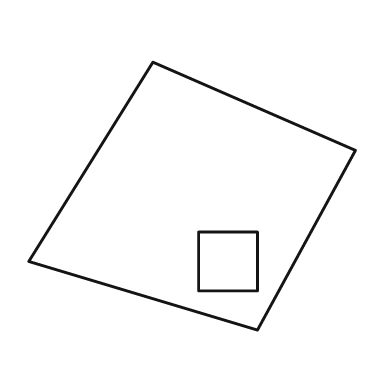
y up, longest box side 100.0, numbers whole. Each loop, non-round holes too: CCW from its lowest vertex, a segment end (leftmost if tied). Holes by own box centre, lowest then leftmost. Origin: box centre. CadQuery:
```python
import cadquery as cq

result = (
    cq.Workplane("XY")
    .moveTo(20.0, -41.0)
    .lineTo(50.0, 14.0)
    .lineTo(-12.0, 41.0)
    .lineTo(-50.0, -20.0)
    .close()
    .moveTo(2.0, -29.0)
    .lineTo(20.0, -29.0)
    .lineTo(20.0, -11.0)
    .lineTo(2.0, -11.0)
    .close()
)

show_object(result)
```